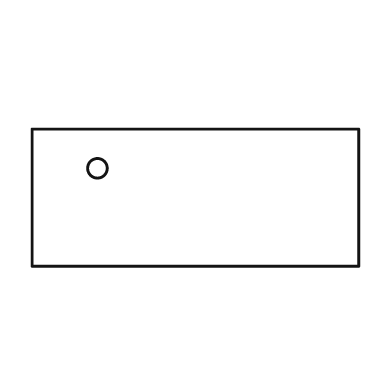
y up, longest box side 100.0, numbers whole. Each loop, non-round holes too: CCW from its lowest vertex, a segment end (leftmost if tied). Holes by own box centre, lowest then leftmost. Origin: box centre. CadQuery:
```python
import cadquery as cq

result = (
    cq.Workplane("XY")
    .moveTo(-50.0, -21.0)
    .lineTo(50.0, -21.0)
    .lineTo(50.0, 21.0)
    .lineTo(-50.0, 21.0)
    .close()
    .moveTo(-30.0, 9.0)
    .circle(3.0)
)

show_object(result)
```